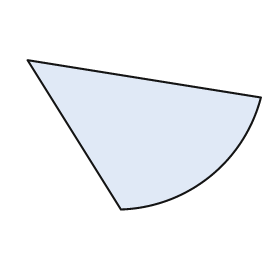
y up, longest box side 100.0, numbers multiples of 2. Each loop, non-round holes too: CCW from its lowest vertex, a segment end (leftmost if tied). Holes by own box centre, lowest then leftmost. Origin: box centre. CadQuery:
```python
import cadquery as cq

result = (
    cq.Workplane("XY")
    .moveTo(-10.0, -32.0)
    .threePointArc((28.0, -18.0), (50.0, 16.0))
    .lineTo(-50.0, 32.0)
    .close()
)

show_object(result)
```